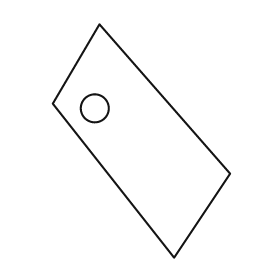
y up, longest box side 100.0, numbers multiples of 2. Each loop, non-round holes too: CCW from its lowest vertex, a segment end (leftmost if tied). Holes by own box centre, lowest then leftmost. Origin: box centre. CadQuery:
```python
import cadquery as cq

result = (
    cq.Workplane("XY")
    .moveTo(14.0, -50.0)
    .lineTo(38.0, -14.0)
    .lineTo(-18.0, 50.0)
    .lineTo(-38.0, 16.0)
    .close()
    .moveTo(-20.0, 14.0)
    .circle(6.0)
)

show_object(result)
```